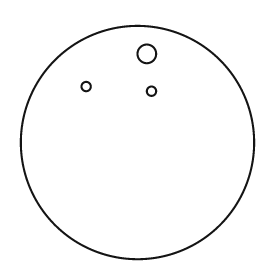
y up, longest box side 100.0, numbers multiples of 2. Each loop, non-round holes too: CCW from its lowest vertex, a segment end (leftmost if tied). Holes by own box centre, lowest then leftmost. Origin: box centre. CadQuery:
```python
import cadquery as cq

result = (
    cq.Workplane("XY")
    .moveTo(0.0, 0.0)
    .circle(50.0)
    .moveTo(6.0, 22.0)
    .circle(2.0)
    .moveTo(-22.0, 24.0)
    .circle(2.0)
    .moveTo(4.0, 38.0)
    .circle(4.0)
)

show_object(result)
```